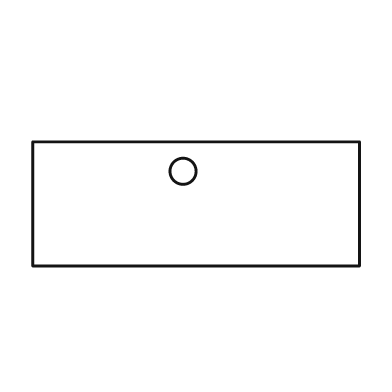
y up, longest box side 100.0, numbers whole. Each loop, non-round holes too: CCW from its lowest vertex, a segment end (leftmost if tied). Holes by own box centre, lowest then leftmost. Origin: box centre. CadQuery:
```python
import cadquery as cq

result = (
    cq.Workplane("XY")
    .moveTo(-50.0, -19.0)
    .lineTo(50.0, -19.0)
    .lineTo(50.0, 19.0)
    .lineTo(-50.0, 19.0)
    .close()
    .moveTo(-4.0, 10.0)
    .circle(4.0)
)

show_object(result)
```